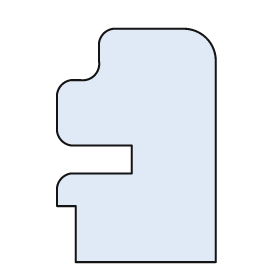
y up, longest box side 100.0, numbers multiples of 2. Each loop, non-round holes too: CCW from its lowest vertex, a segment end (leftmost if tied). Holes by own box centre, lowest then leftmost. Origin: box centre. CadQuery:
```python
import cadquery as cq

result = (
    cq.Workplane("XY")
    .moveTo(-26.0, -50.0)
    .lineTo(34.0, -50.0)
    .lineTo(34.0, 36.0)
    .threePointArc((30.0, 46.0), (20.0, 50.0))
    .lineTo(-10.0, 50.0)
    .threePointArc((-14.0, 48.0), (-16.0, 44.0))
    .lineTo(-16.0, 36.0)
    .threePointArc((-18.0, 30.0), (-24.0, 28.0))
    .lineTo(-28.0, 28.0)
    .threePointArc((-32.0, 26.0), (-34.0, 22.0))
    .lineTo(-34.0, 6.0)
    .threePointArc((-32.0, 2.0), (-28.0, 0.0))
    .lineTo(-2.0, 0.0)
    .lineTo(-2.0, -12.0)
    .lineTo(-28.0, -12.0)
    .threePointArc((-32.0, -14.0), (-34.0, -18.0))
    .lineTo(-34.0, -26.0)
    .lineTo(-26.0, -26.0)
    .close()
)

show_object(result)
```